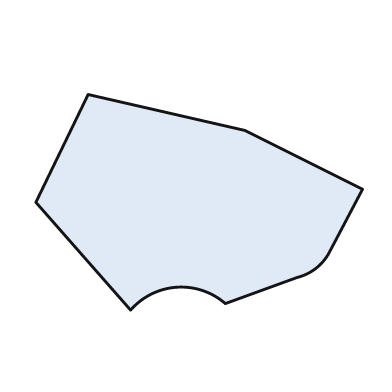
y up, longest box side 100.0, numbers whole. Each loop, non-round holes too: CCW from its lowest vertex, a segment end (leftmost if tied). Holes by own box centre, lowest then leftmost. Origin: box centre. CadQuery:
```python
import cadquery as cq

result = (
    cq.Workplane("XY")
    .moveTo(-21.0, -33.0)
    .threePointArc((-7.0, -26.0), (8.0, -31.0))
    .lineTo(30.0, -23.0)
    .threePointArc((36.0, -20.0), (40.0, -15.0))
    .lineTo(50.0, 4.0)
    .lineTo(14.0, 22.0)
    .lineTo(-34.0, 33.0)
    .lineTo(-50.0, 0.0)
    .close()
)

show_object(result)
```